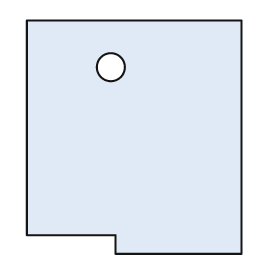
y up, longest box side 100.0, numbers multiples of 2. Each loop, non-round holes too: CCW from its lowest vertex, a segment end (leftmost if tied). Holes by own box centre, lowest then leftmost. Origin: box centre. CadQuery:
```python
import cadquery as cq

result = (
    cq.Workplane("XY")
    .moveTo(-8.0, -50.0)
    .lineTo(46.0, -50.0)
    .lineTo(46.0, 50.0)
    .lineTo(-46.0, 50.0)
    .lineTo(-46.0, -42.0)
    .lineTo(-8.0, -42.0)
    .close()
    .moveTo(-10.0, 30.0)
    .circle(6.0)
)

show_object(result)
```